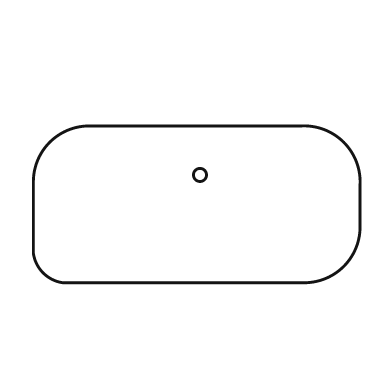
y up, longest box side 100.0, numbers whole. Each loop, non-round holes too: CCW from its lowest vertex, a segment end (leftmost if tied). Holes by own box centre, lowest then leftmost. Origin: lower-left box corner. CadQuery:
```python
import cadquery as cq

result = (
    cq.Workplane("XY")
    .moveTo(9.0, 0.0)
    .lineTo(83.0, 0.0)
    .threePointArc((95.0, 5.0), (100.0, 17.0))
    .lineTo(100.0, 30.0)
    .threePointArc((95.0, 43.0), (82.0, 48.0))
    .lineTo(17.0, 48.0)
    .threePointArc((5.0, 43.0), (0.0, 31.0))
    .lineTo(0.0, 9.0)
    .threePointArc((3.0, 3.0), (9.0, 0.0))
    .close()
    .moveTo(51.0, 33.0)
    .circle(2.0)
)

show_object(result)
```